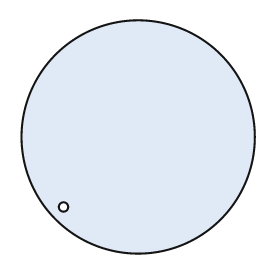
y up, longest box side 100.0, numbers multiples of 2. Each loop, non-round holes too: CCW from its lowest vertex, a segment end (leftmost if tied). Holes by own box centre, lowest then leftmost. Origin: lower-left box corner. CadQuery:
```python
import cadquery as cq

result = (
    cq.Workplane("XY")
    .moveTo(50.0, 50.0)
    .circle(50.0)
    .moveTo(18.0, 20.0)
    .circle(2.0)
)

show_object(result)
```